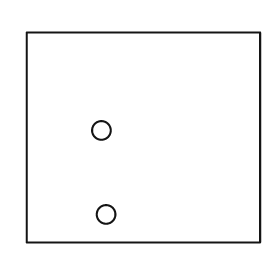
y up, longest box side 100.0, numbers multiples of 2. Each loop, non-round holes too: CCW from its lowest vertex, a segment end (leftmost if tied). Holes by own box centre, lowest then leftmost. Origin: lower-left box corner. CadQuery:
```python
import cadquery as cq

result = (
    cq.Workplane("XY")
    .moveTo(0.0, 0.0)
    .lineTo(100.0, 0.0)
    .lineTo(100.0, 90.0)
    .lineTo(0.0, 90.0)
    .close()
    .moveTo(34.0, 12.0)
    .circle(4.0)
    .moveTo(32.0, 48.0)
    .circle(4.0)
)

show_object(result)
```